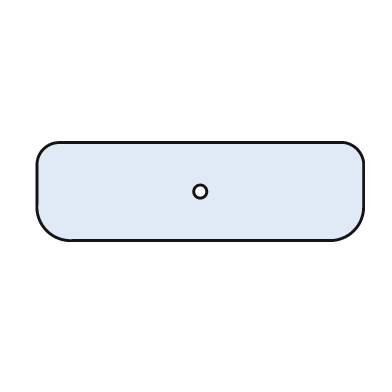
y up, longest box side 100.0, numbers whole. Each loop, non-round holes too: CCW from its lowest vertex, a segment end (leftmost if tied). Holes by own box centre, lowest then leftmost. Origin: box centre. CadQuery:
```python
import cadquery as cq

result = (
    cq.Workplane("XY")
    .moveTo(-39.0, -15.0)
    .lineTo(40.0, -15.0)
    .threePointArc((47.0, -12.0), (50.0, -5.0))
    .lineTo(50.0, 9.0)
    .threePointArc((48.0, 13.0), (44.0, 15.0))
    .lineTo(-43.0, 15.0)
    .threePointArc((-48.0, 13.0), (-50.0, 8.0))
    .lineTo(-50.0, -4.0)
    .threePointArc((-47.0, -12.0), (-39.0, -15.0))
    .close()
    .moveTo(0.0, 0.0)
    .circle(2.0)
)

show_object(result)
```